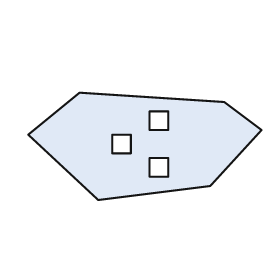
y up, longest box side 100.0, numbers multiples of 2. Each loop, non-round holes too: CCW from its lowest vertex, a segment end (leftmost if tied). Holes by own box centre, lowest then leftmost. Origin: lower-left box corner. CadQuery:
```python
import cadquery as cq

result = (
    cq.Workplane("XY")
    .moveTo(30.0, 0.0)
    .lineTo(78.0, 6.0)
    .lineTo(100.0, 30.0)
    .lineTo(84.0, 42.0)
    .lineTo(22.0, 46.0)
    .lineTo(0.0, 28.0)
    .close()
    .moveTo(52.0, 10.0)
    .lineTo(60.0, 10.0)
    .lineTo(60.0, 18.0)
    .lineTo(52.0, 18.0)
    .close()
    .moveTo(36.0, 20.0)
    .lineTo(44.0, 20.0)
    .lineTo(44.0, 28.0)
    .lineTo(36.0, 28.0)
    .close()
    .moveTo(52.0, 30.0)
    .lineTo(60.0, 30.0)
    .lineTo(60.0, 38.0)
    .lineTo(52.0, 38.0)
    .close()
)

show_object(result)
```